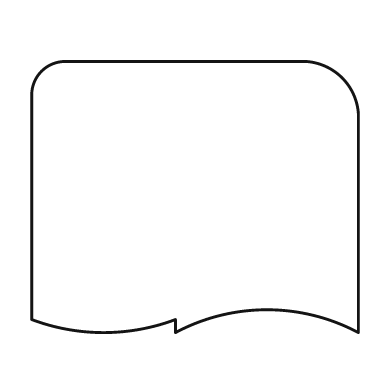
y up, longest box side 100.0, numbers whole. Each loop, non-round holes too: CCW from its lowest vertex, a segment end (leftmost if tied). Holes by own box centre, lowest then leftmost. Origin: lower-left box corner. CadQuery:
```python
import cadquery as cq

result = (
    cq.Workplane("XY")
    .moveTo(44.0, 0.0)
    .threePointArc((72.0, 7.0), (100.0, 0.0))
    .lineTo(100.0, 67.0)
    .threePointArc((95.0, 78.0), (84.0, 83.0))
    .lineTo(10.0, 83.0)
    .threePointArc((3.0, 80.0), (0.0, 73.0))
    .lineTo(0.0, 4.0)
    .threePointArc((22.0, 0.0), (44.0, 4.0))
    .close()
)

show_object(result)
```